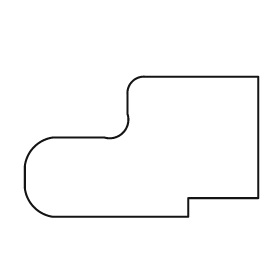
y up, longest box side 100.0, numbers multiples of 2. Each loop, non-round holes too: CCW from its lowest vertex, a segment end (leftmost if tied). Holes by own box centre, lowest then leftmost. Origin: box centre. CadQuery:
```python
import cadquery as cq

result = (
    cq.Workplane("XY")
    .moveTo(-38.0, -30.0)
    .lineTo(20.0, -30.0)
    .lineTo(20.0, -22.0)
    .lineTo(50.0, -22.0)
    .lineTo(50.0, 30.0)
    .lineTo(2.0, 30.0)
    .threePointArc((-4.0, 28.0), (-6.0, 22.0))
    .lineTo(-6.0, 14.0)
    .threePointArc((-8.0, 6.0), (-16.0, 4.0))
    .lineTo(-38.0, 4.0)
    .threePointArc((-46.0, 0.0), (-50.0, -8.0))
    .lineTo(-50.0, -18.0)
    .threePointArc((-46.0, -26.0), (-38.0, -30.0))
    .close()
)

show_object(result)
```